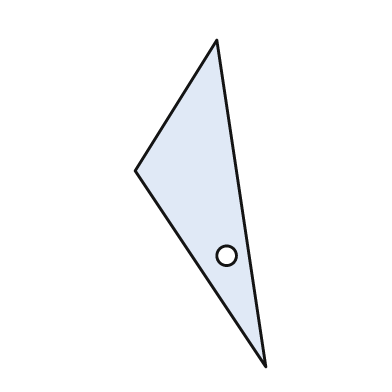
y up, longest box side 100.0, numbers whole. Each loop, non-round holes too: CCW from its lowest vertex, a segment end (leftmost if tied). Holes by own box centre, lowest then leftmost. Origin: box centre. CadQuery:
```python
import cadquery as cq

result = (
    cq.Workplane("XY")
    .moveTo(20.0, -50.0)
    .lineTo(5.0, 50.0)
    .lineTo(-20.0, 10.0)
    .close()
    .moveTo(8.0, -16.0)
    .circle(3.0)
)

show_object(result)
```